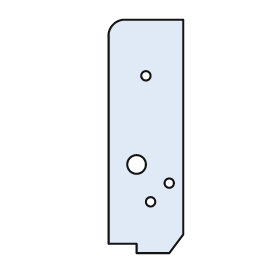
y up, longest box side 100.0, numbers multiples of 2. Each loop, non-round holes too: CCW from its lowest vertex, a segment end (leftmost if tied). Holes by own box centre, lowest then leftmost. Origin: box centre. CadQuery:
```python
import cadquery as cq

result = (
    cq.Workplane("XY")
    .moveTo(-4.0, -50.0)
    .lineTo(10.0, -50.0)
    .lineTo(16.0, -42.0)
    .lineTo(16.0, 50.0)
    .lineTo(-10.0, 50.0)
    .threePointArc((-14.0, 48.0), (-16.0, 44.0))
    .lineTo(-16.0, -46.0)
    .lineTo(-4.0, -46.0)
    .close()
    .moveTo(2.0, -28.0)
    .circle(2.0)
    .moveTo(10.0, -20.0)
    .circle(2.0)
    .moveTo(-4.0, -12.0)
    .circle(4.0)
    .moveTo(0.0, 26.0)
    .circle(2.0)
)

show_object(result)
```